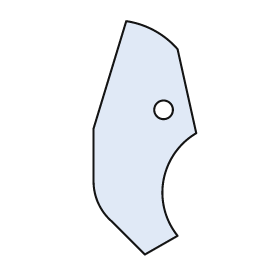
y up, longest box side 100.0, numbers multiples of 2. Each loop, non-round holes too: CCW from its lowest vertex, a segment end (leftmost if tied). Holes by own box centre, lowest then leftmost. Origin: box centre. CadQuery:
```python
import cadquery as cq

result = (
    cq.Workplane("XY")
    .moveTo(0.0, -50.0)
    .lineTo(14.0, -42.0)
    .threePointArc((8.0, -18.0), (22.0, 2.0))
    .lineTo(14.0, 38.0)
    .threePointArc((4.0, 46.0), (-8.0, 50.0))
    .lineTo(-22.0, 4.0)
    .lineTo(-22.0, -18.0)
    .threePointArc((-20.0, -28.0), (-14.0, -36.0))
    .close()
    .moveTo(8.0, 12.0)
    .circle(4.0)
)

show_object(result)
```